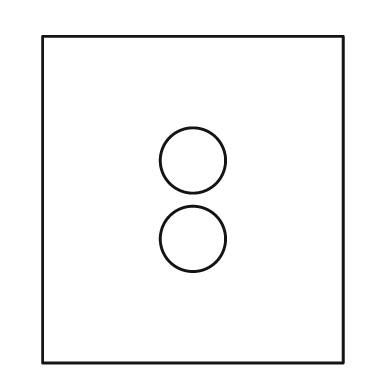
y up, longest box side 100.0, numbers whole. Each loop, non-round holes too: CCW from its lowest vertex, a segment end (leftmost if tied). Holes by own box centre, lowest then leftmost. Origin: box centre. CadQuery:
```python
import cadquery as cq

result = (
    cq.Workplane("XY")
    .moveTo(-46.0, -50.0)
    .lineTo(46.0, -50.0)
    .lineTo(46.0, 50.0)
    .lineTo(-46.0, 50.0)
    .close()
    .moveTo(0.0, -12.0)
    .circle(10.0)
    .moveTo(0.0, 12.0)
    .circle(10.0)
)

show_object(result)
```